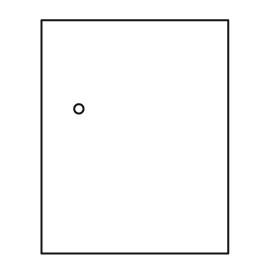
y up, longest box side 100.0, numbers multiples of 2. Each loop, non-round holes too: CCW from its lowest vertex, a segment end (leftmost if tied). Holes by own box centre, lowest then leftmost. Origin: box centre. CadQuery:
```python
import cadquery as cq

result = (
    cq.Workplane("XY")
    .moveTo(-40.0, -50.0)
    .lineTo(40.0, -50.0)
    .lineTo(40.0, 50.0)
    .lineTo(-40.0, 50.0)
    .close()
    .moveTo(-24.0, 12.0)
    .circle(2.0)
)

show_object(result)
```